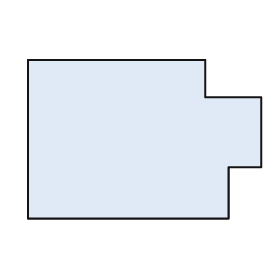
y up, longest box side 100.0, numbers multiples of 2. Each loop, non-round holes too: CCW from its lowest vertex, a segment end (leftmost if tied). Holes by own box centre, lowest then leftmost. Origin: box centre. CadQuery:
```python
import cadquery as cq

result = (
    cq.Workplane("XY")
    .moveTo(-50.0, -34.0)
    .lineTo(36.0, -34.0)
    .lineTo(36.0, -12.0)
    .lineTo(50.0, -12.0)
    .lineTo(50.0, 18.0)
    .lineTo(26.0, 18.0)
    .lineTo(26.0, 34.0)
    .lineTo(-50.0, 34.0)
    .close()
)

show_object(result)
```